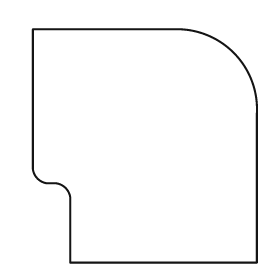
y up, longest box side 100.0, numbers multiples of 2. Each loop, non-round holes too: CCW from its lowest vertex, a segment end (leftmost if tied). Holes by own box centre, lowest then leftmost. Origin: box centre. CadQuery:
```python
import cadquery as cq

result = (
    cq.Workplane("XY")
    .moveTo(-32.0, -50.0)
    .lineTo(48.0, -50.0)
    .lineTo(48.0, 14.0)
    .threePointArc((38.0, 40.0), (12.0, 50.0))
    .lineTo(-48.0, 50.0)
    .lineTo(-48.0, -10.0)
    .threePointArc((-46.0, -14.0), (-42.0, -16.0))
    .lineTo(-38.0, -16.0)
    .threePointArc((-34.0, -18.0), (-32.0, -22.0))
    .close()
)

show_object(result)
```